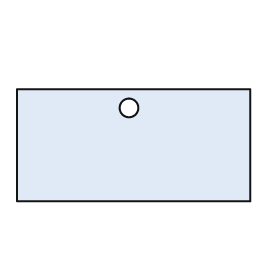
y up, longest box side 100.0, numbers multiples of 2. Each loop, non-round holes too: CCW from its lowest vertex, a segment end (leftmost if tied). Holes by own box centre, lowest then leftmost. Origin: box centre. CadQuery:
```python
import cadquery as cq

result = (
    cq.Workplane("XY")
    .moveTo(-50.0, -24.0)
    .lineTo(50.0, -24.0)
    .lineTo(50.0, 24.0)
    .lineTo(-50.0, 24.0)
    .close()
    .moveTo(-2.0, 16.0)
    .circle(4.0)
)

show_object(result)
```